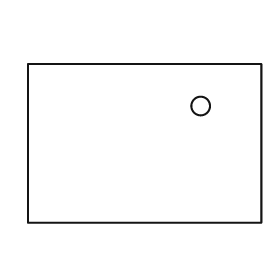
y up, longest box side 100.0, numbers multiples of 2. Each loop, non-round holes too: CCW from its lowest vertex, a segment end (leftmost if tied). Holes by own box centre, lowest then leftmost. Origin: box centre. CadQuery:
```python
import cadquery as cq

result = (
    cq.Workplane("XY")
    .moveTo(-50.0, -34.0)
    .lineTo(50.0, -34.0)
    .lineTo(50.0, 34.0)
    .lineTo(-50.0, 34.0)
    .close()
    .moveTo(24.0, 16.0)
    .circle(4.0)
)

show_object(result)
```